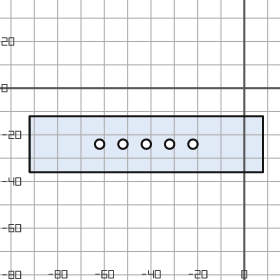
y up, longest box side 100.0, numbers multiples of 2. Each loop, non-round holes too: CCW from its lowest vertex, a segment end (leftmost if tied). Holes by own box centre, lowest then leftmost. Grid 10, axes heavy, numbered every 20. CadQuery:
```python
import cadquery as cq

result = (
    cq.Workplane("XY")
    .moveTo(-92.0, -36.0)
    .lineTo(8.0, -36.0)
    .lineTo(8.0, -12.0)
    .lineTo(-92.0, -12.0)
    .close()
    .moveTo(-62.0, -24.0)
    .circle(2.0)
    .moveTo(-52.0, -24.0)
    .circle(2.0)
    .moveTo(-42.0, -24.0)
    .circle(2.0)
    .moveTo(-32.0, -24.0)
    .circle(2.0)
    .moveTo(-22.0, -24.0)
    .circle(2.0)
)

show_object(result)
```